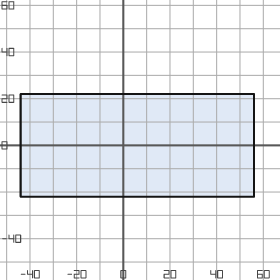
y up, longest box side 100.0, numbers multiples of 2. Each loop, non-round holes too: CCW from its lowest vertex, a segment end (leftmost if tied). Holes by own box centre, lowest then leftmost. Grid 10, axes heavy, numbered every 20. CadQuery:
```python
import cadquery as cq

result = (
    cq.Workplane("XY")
    .moveTo(-44.0, -22.0)
    .lineTo(56.0, -22.0)
    .lineTo(56.0, 22.0)
    .lineTo(-44.0, 22.0)
    .close()
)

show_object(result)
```